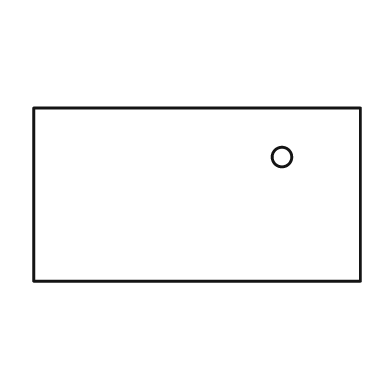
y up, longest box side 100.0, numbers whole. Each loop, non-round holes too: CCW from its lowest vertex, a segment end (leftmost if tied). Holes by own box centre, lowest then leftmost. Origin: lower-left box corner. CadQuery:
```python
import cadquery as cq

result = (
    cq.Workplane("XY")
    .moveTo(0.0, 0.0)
    .lineTo(100.0, 0.0)
    .lineTo(100.0, 53.0)
    .lineTo(0.0, 53.0)
    .close()
    .moveTo(76.0, 38.0)
    .circle(3.0)
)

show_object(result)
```